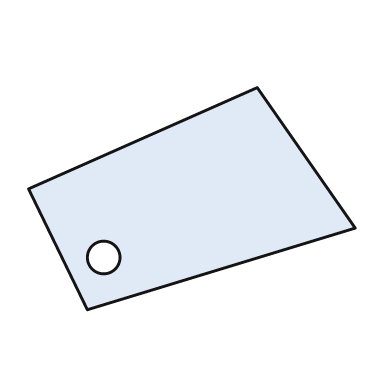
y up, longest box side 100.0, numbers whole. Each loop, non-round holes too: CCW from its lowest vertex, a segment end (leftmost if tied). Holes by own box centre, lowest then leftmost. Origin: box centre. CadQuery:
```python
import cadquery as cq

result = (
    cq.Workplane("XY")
    .moveTo(-32.0, -34.0)
    .lineTo(50.0, -9.0)
    .lineTo(20.0, 34.0)
    .lineTo(-50.0, 3.0)
    .close()
    .moveTo(-27.0, -18.0)
    .circle(5.0)
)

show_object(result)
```